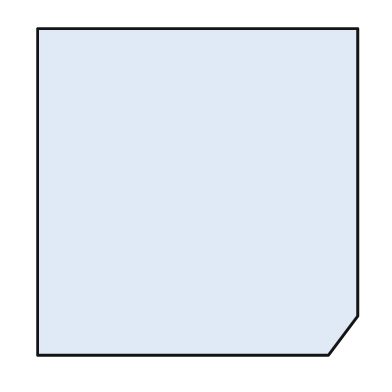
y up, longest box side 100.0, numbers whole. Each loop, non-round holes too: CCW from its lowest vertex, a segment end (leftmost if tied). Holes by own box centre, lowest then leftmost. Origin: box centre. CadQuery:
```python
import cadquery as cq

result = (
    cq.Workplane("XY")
    .moveTo(-49.0, -50.0)
    .lineTo(40.0, -50.0)
    .lineTo(49.0, -38.0)
    .lineTo(49.0, 50.0)
    .lineTo(-49.0, 50.0)
    .close()
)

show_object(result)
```